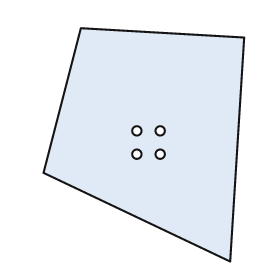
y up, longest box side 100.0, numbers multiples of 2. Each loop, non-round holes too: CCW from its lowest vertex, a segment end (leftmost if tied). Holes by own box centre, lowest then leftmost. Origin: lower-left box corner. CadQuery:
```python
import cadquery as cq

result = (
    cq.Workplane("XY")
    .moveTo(80.0, 0.0)
    .lineTo(86.0, 96.0)
    .lineTo(16.0, 100.0)
    .lineTo(0.0, 38.0)
    .close()
    .moveTo(40.0, 46.0)
    .circle(2.0)
    .moveTo(50.0, 46.0)
    .circle(2.0)
    .moveTo(40.0, 56.0)
    .circle(2.0)
    .moveTo(50.0, 56.0)
    .circle(2.0)
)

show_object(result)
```